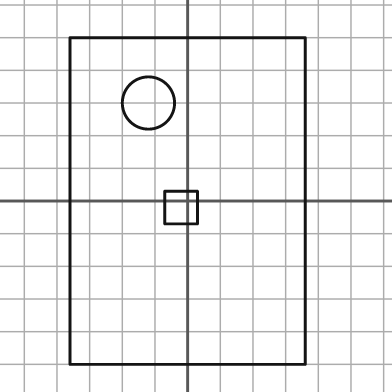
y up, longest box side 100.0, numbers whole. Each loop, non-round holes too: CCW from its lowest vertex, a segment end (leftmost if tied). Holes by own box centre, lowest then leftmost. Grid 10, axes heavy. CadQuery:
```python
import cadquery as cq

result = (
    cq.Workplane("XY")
    .moveTo(-36.0, -50.0)
    .lineTo(36.0, -50.0)
    .lineTo(36.0, 50.0)
    .lineTo(-36.0, 50.0)
    .close()
    .moveTo(-7.0, -7.0)
    .lineTo(3.0, -7.0)
    .lineTo(3.0, 3.0)
    .lineTo(-7.0, 3.0)
    .close()
    .moveTo(-12.0, 30.0)
    .circle(8.0)
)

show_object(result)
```